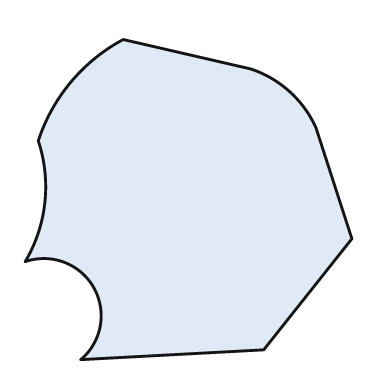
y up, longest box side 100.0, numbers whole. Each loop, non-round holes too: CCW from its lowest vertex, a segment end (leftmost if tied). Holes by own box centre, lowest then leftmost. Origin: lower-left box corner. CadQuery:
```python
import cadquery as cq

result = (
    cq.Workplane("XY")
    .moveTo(17.0, 0.0)
    .lineTo(73.0, 3.0)
    .lineTo(100.0, 37.0)
    .lineTo(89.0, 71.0)
    .threePointArc((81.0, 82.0), (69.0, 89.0))
    .lineTo(30.0, 98.0)
    .threePointArc((14.0, 85.0), (4.0, 67.0))
    .threePointArc((6.0, 48.0), (0.0, 30.0))
    .threePointArc((21.0, 22.0), (17.0, 0.0))
    .close()
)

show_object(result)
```